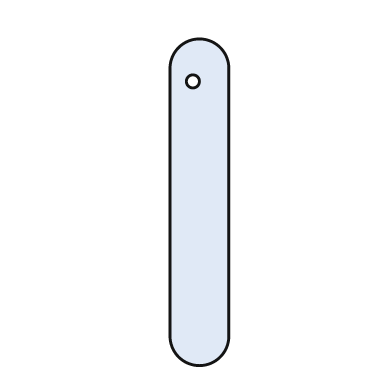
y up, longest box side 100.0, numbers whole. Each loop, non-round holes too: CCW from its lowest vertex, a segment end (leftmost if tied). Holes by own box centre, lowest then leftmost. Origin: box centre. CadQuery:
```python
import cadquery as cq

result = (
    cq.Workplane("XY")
    .moveTo(-9.0, -41.0)
    .threePointArc((0.0, -50.0), (9.0, -41.0))
    .lineTo(9.0, 41.0)
    .threePointArc((0.0, 50.0), (-9.0, 41.0))
    .close()
    .moveTo(-2.0, 37.0)
    .circle(2.0)
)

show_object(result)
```